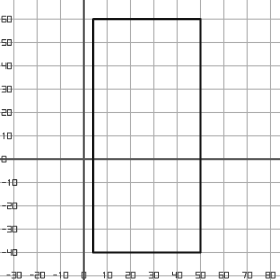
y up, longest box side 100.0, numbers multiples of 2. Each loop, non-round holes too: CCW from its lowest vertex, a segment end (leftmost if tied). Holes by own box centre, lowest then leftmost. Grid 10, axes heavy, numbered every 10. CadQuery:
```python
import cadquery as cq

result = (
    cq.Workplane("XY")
    .moveTo(4.0, -40.0)
    .lineTo(50.0, -40.0)
    .lineTo(50.0, 60.0)
    .lineTo(4.0, 60.0)
    .close()
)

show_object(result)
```